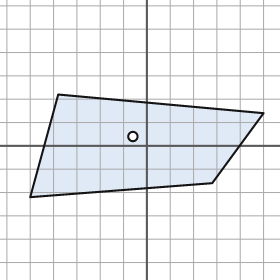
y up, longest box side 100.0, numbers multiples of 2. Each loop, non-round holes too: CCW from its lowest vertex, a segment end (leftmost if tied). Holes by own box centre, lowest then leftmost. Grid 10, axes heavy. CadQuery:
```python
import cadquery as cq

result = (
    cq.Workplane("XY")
    .moveTo(-50.0, -22.0)
    .lineTo(28.0, -16.0)
    .lineTo(50.0, 14.0)
    .lineTo(-38.0, 22.0)
    .close()
    .moveTo(-6.0, 4.0)
    .circle(2.0)
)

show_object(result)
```